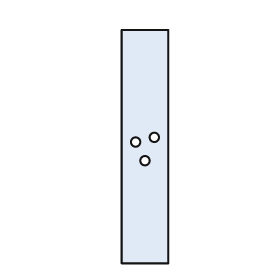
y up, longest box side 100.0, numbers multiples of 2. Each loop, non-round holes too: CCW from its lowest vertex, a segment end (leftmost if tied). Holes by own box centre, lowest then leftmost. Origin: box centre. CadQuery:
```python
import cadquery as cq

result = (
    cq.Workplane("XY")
    .moveTo(-10.0, -50.0)
    .lineTo(10.0, -50.0)
    .lineTo(10.0, 50.0)
    .lineTo(-10.0, 50.0)
    .close()
    .moveTo(0.0, -6.0)
    .circle(2.0)
    .moveTo(-4.0, 2.0)
    .circle(2.0)
    .moveTo(4.0, 4.0)
    .circle(2.0)
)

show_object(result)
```